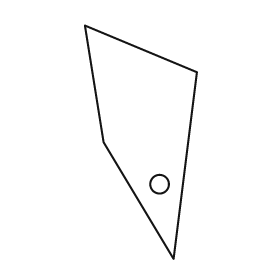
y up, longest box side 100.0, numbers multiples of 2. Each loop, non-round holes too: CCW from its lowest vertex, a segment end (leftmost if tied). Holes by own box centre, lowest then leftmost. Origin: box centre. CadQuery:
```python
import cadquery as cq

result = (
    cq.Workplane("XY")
    .moveTo(14.0, -50.0)
    .lineTo(24.0, 30.0)
    .lineTo(-24.0, 50.0)
    .lineTo(-16.0, 0.0)
    .close()
    .moveTo(8.0, -18.0)
    .circle(4.0)
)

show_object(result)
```